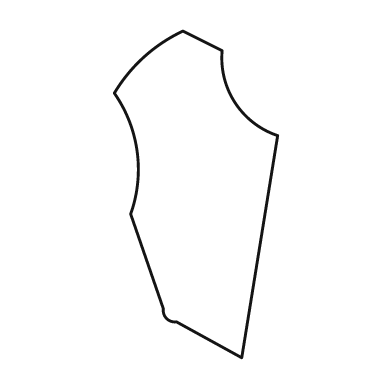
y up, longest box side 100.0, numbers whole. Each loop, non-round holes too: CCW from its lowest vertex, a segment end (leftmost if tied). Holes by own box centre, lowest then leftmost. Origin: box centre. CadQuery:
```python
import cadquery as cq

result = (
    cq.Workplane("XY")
    .moveTo(14.0, -50.0)
    .lineTo(25.0, 18.0)
    .threePointArc((12.0, 28.0), (8.0, 44.0))
    .lineTo(-4.0, 50.0)
    .threePointArc((-16.0, 42.0), (-25.0, 31.0))
    .threePointArc((-18.0, 13.0), (-20.0, -6.0))
    .lineTo(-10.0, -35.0)
    .threePointArc((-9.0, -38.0), (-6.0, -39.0))
    .close()
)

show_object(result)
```